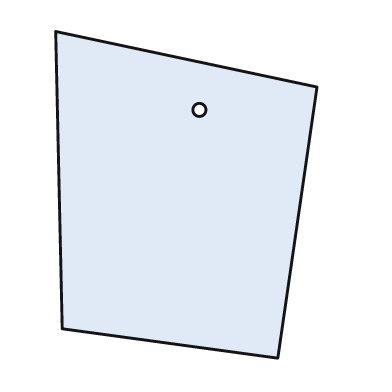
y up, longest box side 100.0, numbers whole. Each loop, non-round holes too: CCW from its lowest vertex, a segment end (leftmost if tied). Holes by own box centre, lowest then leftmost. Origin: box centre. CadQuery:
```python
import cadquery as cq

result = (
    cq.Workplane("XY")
    .moveTo(28.0, -50.0)
    .lineTo(40.0, 33.0)
    .lineTo(-40.0, 50.0)
    .lineTo(-38.0, -41.0)
    .close()
    .moveTo(4.0, 26.0)
    .circle(2.0)
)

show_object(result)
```